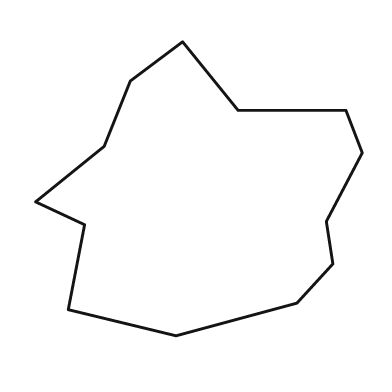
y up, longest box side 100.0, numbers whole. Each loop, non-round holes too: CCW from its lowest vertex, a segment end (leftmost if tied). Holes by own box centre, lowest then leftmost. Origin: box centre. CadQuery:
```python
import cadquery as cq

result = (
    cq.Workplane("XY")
    .moveTo(-7.0, -45.0)
    .lineTo(30.0, -35.0)
    .lineTo(41.0, -23.0)
    .lineTo(39.0, -10.0)
    .lineTo(50.0, 11.0)
    .lineTo(45.0, 24.0)
    .lineTo(12.0, 24.0)
    .lineTo(-5.0, 45.0)
    .lineTo(-21.0, 33.0)
    .lineTo(-29.0, 13.0)
    .lineTo(-50.0, -4.0)
    .lineTo(-35.0, -11.0)
    .lineTo(-40.0, -37.0)
    .close()
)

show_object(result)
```